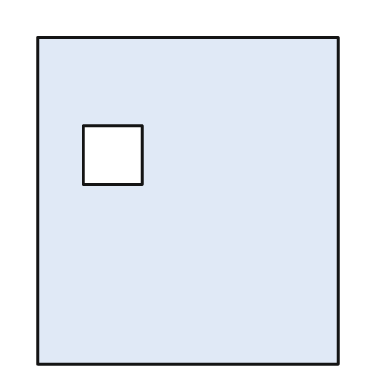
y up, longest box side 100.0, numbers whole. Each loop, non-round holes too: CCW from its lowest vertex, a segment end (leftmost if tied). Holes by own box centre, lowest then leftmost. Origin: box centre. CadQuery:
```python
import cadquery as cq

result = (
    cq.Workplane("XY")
    .moveTo(-46.0, -50.0)
    .lineTo(46.0, -50.0)
    .lineTo(46.0, 50.0)
    .lineTo(-46.0, 50.0)
    .close()
    .moveTo(-32.0, 5.0)
    .lineTo(-14.0, 5.0)
    .lineTo(-14.0, 23.0)
    .lineTo(-32.0, 23.0)
    .close()
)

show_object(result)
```